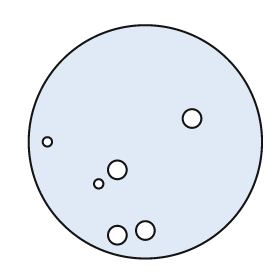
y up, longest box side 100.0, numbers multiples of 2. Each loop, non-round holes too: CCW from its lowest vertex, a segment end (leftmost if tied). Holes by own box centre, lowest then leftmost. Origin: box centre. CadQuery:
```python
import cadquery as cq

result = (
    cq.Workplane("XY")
    .moveTo(0.0, 0.0)
    .circle(50.0)
    .moveTo(-12.0, -40.0)
    .circle(4.0)
    .moveTo(0.0, -38.0)
    .circle(4.0)
    .moveTo(-20.0, -18.0)
    .circle(2.0)
    .moveTo(-12.0, -12.0)
    .circle(4.0)
    .moveTo(-42.0, 0.0)
    .circle(2.0)
    .moveTo(20.0, 10.0)
    .circle(4.0)
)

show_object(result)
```